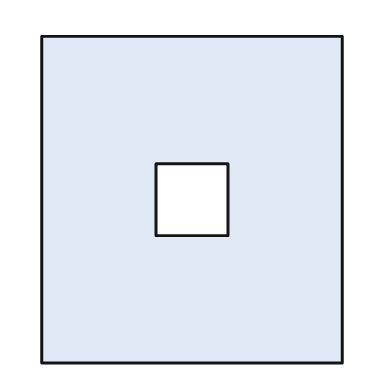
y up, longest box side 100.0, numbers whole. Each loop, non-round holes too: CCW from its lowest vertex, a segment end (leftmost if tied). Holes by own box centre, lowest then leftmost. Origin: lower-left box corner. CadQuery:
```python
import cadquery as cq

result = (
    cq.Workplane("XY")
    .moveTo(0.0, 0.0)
    .lineTo(92.0, 0.0)
    .lineTo(92.0, 100.0)
    .lineTo(0.0, 100.0)
    .close()
    .moveTo(35.0, 39.0)
    .lineTo(57.0, 39.0)
    .lineTo(57.0, 61.0)
    .lineTo(35.0, 61.0)
    .close()
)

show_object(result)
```